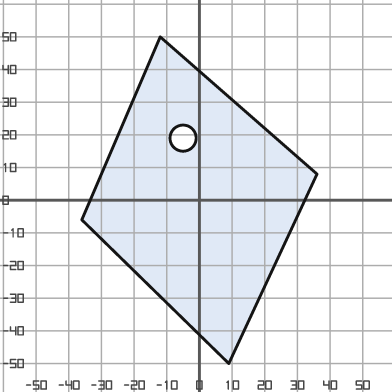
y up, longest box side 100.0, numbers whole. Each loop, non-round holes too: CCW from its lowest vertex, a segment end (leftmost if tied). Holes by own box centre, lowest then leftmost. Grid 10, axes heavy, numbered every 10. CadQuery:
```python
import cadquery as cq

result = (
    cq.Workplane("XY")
    .moveTo(9.0, -50.0)
    .lineTo(36.0, 8.0)
    .lineTo(-12.0, 50.0)
    .lineTo(-36.0, -6.0)
    .close()
    .moveTo(-5.0, 19.0)
    .circle(4.0)
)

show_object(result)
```